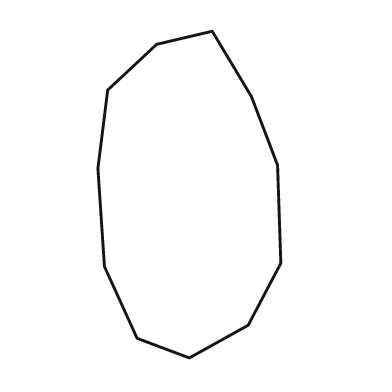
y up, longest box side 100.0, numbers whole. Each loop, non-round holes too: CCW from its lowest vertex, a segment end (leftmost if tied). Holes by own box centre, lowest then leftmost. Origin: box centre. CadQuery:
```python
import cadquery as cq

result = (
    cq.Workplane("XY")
    .moveTo(0.0, -50.0)
    .lineTo(18.0, -40.0)
    .lineTo(28.0, -21.0)
    .lineTo(27.0, 9.0)
    .lineTo(19.0, 30.0)
    .lineTo(7.0, 50.0)
    .lineTo(-10.0, 46.0)
    .lineTo(-25.0, 32.0)
    .lineTo(-28.0, 8.0)
    .lineTo(-26.0, -22.0)
    .lineTo(-16.0, -44.0)
    .close()
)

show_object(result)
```